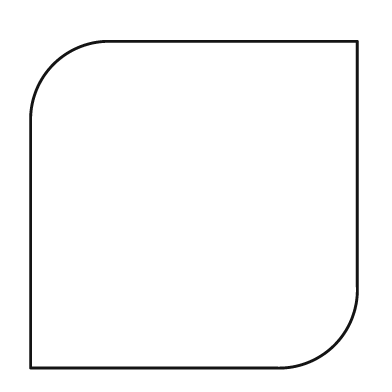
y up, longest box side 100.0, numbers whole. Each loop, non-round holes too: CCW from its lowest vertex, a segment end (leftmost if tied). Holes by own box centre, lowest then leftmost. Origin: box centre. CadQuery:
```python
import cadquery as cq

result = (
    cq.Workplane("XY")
    .moveTo(-50.0, -50.0)
    .lineTo(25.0, -50.0)
    .threePointArc((43.0, -43.0), (50.0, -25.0))
    .lineTo(50.0, 50.0)
    .lineTo(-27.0, 50.0)
    .threePointArc((-43.0, 43.0), (-50.0, 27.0))
    .close()
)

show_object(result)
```